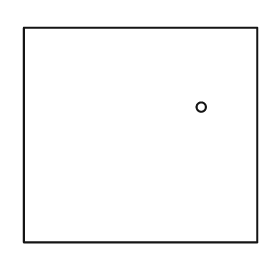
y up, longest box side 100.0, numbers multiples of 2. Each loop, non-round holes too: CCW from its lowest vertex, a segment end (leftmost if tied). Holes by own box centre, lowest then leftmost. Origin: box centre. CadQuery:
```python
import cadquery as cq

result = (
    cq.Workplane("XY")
    .moveTo(-50.0, -46.0)
    .lineTo(50.0, -46.0)
    .lineTo(50.0, 46.0)
    .lineTo(-50.0, 46.0)
    .close()
    .moveTo(26.0, 12.0)
    .circle(2.0)
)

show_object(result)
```